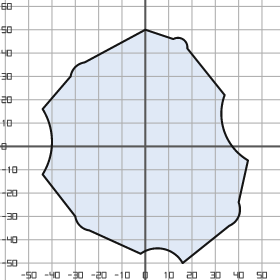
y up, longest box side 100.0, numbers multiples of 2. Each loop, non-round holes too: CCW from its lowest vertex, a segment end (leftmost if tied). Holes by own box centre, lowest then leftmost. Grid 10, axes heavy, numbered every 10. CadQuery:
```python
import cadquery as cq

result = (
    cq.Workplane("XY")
    .moveTo(16.0, -50.0)
    .lineTo(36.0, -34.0)
    .threePointArc((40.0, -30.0), (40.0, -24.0))
    .lineTo(44.0, -6.0)
    .threePointArc((34.0, 6.0), (34.0, 22.0))
    .lineTo(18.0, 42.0)
    .threePointArc((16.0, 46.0), (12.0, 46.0))
    .lineTo(0.0, 50.0)
    .lineTo(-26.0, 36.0)
    .threePointArc((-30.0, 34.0), (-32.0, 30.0))
    .lineTo(-44.0, 16.0)
    .threePointArc((-40.0, 2.0), (-44.0, -12.0))
    .lineTo(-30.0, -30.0)
    .threePointArc((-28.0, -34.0), (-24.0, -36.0))
    .lineTo(-2.0, -46.0)
    .threePointArc((8.0, -44.0), (16.0, -50.0))
    .close()
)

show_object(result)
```